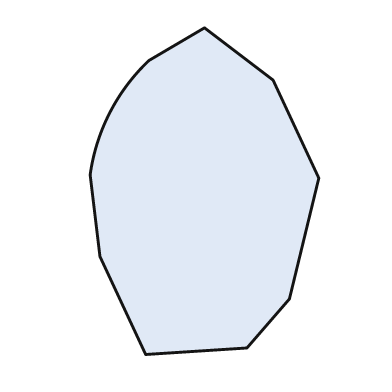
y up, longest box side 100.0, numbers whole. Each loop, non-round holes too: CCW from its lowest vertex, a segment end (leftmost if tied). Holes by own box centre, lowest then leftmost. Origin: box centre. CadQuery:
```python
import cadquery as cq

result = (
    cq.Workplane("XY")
    .moveTo(-18.0, -50.0)
    .lineTo(13.0, -48.0)
    .lineTo(26.0, -33.0)
    .lineTo(35.0, 4.0)
    .lineTo(21.0, 34.0)
    .lineTo(0.0, 50.0)
    .lineTo(-17.0, 40.0)
    .threePointArc((-29.0, 24.0), (-35.0, 5.0))
    .lineTo(-32.0, -20.0)
    .close()
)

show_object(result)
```